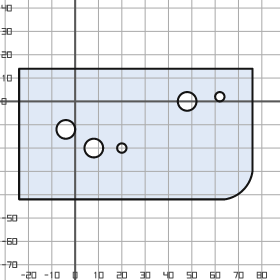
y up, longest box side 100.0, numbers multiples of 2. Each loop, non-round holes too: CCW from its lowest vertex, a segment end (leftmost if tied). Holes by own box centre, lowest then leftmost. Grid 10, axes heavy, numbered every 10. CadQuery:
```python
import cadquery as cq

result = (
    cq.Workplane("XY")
    .moveTo(-24.0, -42.0)
    .lineTo(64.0, -42.0)
    .threePointArc((72.0, -38.0), (76.0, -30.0))
    .lineTo(76.0, 14.0)
    .lineTo(-24.0, 14.0)
    .close()
    .moveTo(8.0, -20.0)
    .circle(4.0)
    .moveTo(20.0, -20.0)
    .circle(2.0)
    .moveTo(-4.0, -12.0)
    .circle(4.0)
    .moveTo(48.0, 0.0)
    .circle(4.0)
    .moveTo(62.0, 2.0)
    .circle(2.0)
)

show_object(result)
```